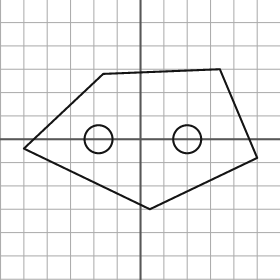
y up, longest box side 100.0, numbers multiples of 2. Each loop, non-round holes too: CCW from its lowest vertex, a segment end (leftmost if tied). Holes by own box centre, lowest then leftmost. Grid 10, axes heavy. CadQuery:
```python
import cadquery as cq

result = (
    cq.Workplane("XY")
    .moveTo(4.0, -30.0)
    .lineTo(50.0, -8.0)
    .lineTo(34.0, 30.0)
    .lineTo(-16.0, 28.0)
    .lineTo(-50.0, -4.0)
    .close()
    .moveTo(-18.0, 0.0)
    .circle(6.0)
    .moveTo(20.0, 0.0)
    .circle(6.0)
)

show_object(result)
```